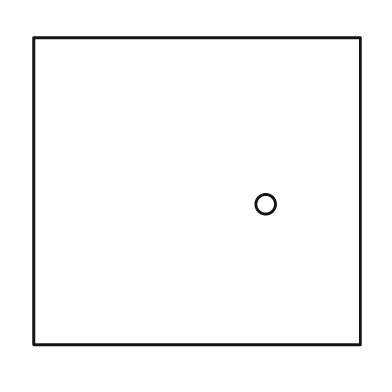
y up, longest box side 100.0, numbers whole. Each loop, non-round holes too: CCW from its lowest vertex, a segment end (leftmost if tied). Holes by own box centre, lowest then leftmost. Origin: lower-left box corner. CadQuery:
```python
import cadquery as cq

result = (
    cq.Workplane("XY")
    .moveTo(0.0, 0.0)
    .lineTo(100.0, 0.0)
    .lineTo(100.0, 94.0)
    .lineTo(0.0, 94.0)
    .close()
    .moveTo(71.0, 43.0)
    .circle(3.0)
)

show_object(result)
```